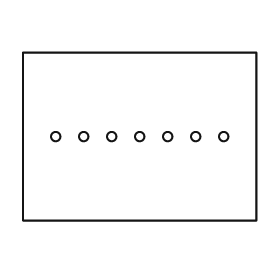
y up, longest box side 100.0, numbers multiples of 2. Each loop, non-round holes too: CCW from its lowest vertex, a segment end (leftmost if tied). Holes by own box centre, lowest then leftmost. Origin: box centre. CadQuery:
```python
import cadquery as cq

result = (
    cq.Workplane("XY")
    .moveTo(-50.0, -36.0)
    .lineTo(50.0, -36.0)
    .lineTo(50.0, 36.0)
    .lineTo(-50.0, 36.0)
    .close()
    .moveTo(-36.0, 0.0)
    .circle(2.0)
    .moveTo(-24.0, 0.0)
    .circle(2.0)
    .moveTo(-12.0, 0.0)
    .circle(2.0)
    .moveTo(0.0, 0.0)
    .circle(2.0)
    .moveTo(12.0, 0.0)
    .circle(2.0)
    .moveTo(24.0, 0.0)
    .circle(2.0)
    .moveTo(36.0, 0.0)
    .circle(2.0)
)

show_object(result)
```